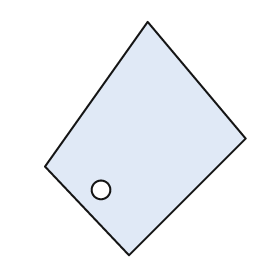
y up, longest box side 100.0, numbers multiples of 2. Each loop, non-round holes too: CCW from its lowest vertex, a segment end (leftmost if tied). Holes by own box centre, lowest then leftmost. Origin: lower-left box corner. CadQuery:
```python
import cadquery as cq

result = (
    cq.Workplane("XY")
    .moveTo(36.0, 0.0)
    .lineTo(86.0, 50.0)
    .lineTo(44.0, 100.0)
    .lineTo(0.0, 38.0)
    .close()
    .moveTo(24.0, 28.0)
    .circle(4.0)
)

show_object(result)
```